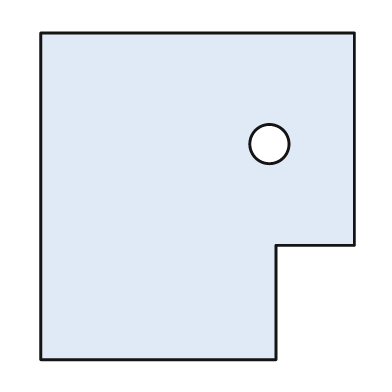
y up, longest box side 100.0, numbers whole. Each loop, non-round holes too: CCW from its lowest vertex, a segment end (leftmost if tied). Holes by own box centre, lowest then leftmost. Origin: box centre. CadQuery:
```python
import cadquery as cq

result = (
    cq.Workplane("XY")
    .moveTo(-48.0, -50.0)
    .lineTo(24.0, -50.0)
    .lineTo(24.0, -15.0)
    .lineTo(48.0, -15.0)
    .lineTo(48.0, 50.0)
    .lineTo(-48.0, 50.0)
    .close()
    .moveTo(22.0, 16.0)
    .circle(6.0)
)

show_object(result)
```